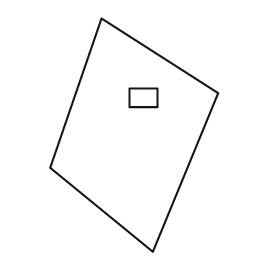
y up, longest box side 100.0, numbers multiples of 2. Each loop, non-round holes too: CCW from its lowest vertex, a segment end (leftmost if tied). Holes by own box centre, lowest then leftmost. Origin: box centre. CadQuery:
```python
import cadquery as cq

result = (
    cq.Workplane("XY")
    .moveTo(8.0, -50.0)
    .lineTo(36.0, 18.0)
    .lineTo(-14.0, 50.0)
    .lineTo(-36.0, -14.0)
    .close()
    .moveTo(-2.0, 12.0)
    .lineTo(10.0, 12.0)
    .lineTo(10.0, 20.0)
    .lineTo(-2.0, 20.0)
    .close()
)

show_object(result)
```